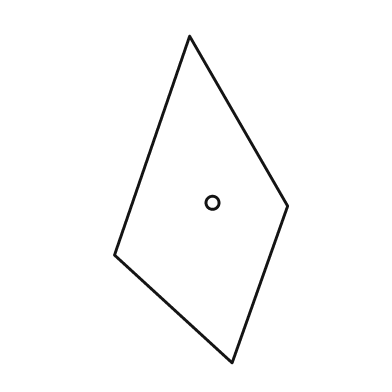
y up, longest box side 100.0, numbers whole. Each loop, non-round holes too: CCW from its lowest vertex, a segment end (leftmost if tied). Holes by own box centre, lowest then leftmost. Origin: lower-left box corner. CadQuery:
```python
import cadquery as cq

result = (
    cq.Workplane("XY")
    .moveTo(36.0, 0.0)
    .lineTo(53.0, 48.0)
    .lineTo(23.0, 100.0)
    .lineTo(0.0, 33.0)
    .close()
    .moveTo(30.0, 49.0)
    .circle(2.0)
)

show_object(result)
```